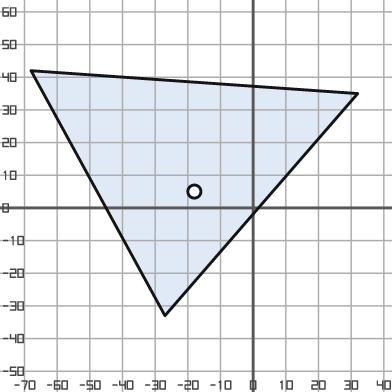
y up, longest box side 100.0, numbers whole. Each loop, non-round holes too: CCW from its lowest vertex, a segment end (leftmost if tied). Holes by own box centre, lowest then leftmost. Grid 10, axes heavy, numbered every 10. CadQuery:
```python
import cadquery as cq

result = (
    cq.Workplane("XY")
    .moveTo(-27.0, -33.0)
    .lineTo(32.0, 35.0)
    .lineTo(-68.0, 42.0)
    .close()
    .moveTo(-18.0, 5.0)
    .circle(2.0)
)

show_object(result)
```